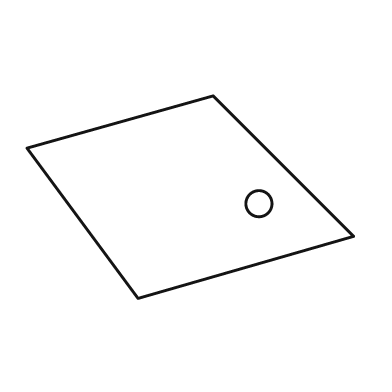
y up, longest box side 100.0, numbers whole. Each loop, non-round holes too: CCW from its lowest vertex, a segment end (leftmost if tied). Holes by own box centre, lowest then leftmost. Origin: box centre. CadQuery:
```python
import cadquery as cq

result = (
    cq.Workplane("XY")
    .moveTo(-16.0, -31.0)
    .lineTo(50.0, -12.0)
    .lineTo(7.0, 31.0)
    .lineTo(-50.0, 15.0)
    .close()
    .moveTo(21.0, -2.0)
    .circle(4.0)
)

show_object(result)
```